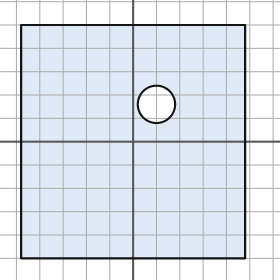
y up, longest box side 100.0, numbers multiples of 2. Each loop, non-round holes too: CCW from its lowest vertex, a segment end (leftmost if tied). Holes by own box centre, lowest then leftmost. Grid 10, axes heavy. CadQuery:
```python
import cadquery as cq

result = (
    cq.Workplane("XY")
    .moveTo(-48.0, -50.0)
    .lineTo(48.0, -50.0)
    .lineTo(48.0, 50.0)
    .lineTo(-48.0, 50.0)
    .close()
    .moveTo(10.0, 16.0)
    .circle(8.0)
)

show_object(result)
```